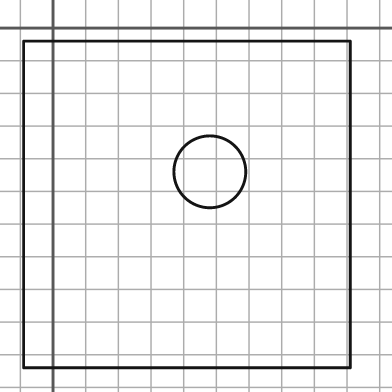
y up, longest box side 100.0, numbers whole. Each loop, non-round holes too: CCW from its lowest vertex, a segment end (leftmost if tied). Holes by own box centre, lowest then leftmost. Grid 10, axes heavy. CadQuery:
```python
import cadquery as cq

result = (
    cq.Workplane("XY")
    .moveTo(-9.0, -104.0)
    .lineTo(91.0, -104.0)
    .lineTo(91.0, -4.0)
    .lineTo(-9.0, -4.0)
    .close()
    .moveTo(48.0, -44.0)
    .circle(11.0)
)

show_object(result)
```